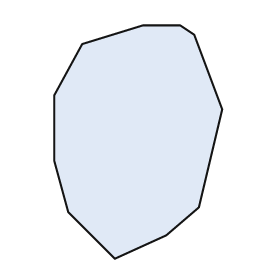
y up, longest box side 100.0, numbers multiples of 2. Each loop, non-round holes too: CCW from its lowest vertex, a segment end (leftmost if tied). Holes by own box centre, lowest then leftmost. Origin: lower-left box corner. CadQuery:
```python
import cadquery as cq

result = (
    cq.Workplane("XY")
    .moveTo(26.0, 0.0)
    .lineTo(48.0, 10.0)
    .lineTo(62.0, 22.0)
    .lineTo(72.0, 64.0)
    .lineTo(60.0, 96.0)
    .lineTo(54.0, 100.0)
    .lineTo(38.0, 100.0)
    .lineTo(12.0, 92.0)
    .lineTo(0.0, 70.0)
    .lineTo(0.0, 42.0)
    .lineTo(6.0, 20.0)
    .close()
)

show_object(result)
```